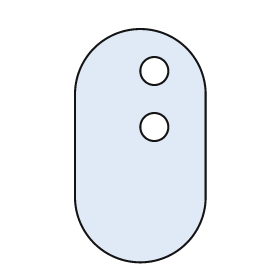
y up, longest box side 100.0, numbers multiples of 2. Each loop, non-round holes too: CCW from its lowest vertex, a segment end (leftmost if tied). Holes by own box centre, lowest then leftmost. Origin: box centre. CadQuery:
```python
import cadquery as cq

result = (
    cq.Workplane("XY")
    .moveTo(-28.0, -22.0)
    .threePointArc((0.0, -50.0), (28.0, -22.0))
    .lineTo(28.0, 22.0)
    .threePointArc((0.0, 50.0), (-28.0, 22.0))
    .close()
    .moveTo(6.0, 8.0)
    .circle(6.0)
    .moveTo(6.0, 32.0)
    .circle(6.0)
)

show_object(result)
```